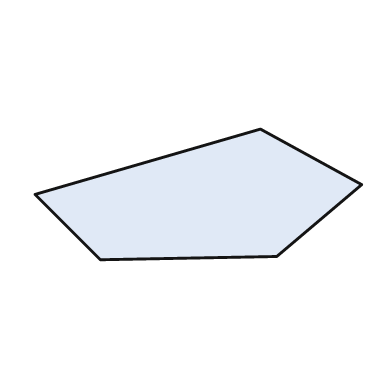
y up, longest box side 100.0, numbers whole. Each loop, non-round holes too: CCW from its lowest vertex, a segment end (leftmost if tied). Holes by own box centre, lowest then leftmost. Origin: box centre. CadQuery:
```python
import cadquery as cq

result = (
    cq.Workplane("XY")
    .moveTo(-30.0, -20.0)
    .lineTo(24.0, -19.0)
    .lineTo(50.0, 3.0)
    .lineTo(19.0, 20.0)
    .lineTo(-50.0, 0.0)
    .close()
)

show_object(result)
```